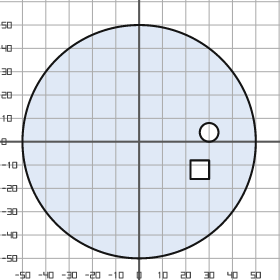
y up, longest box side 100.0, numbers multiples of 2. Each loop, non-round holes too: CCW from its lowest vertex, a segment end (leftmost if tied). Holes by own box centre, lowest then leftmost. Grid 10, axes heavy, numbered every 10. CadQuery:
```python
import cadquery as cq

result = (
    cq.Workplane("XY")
    .moveTo(0.0, 0.0)
    .circle(50.0)
    .moveTo(22.0, -16.0)
    .lineTo(30.0, -16.0)
    .lineTo(30.0, -8.0)
    .lineTo(22.0, -8.0)
    .close()
    .moveTo(30.0, 4.0)
    .circle(4.0)
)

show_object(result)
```